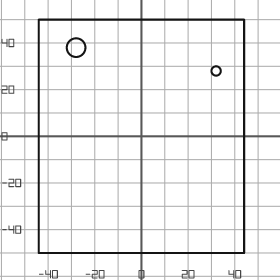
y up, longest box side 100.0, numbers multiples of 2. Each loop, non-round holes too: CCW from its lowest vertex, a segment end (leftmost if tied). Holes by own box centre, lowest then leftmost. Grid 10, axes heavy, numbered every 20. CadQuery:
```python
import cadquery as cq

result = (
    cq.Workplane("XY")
    .moveTo(-44.0, -50.0)
    .lineTo(44.0, -50.0)
    .lineTo(44.0, 50.0)
    .lineTo(-44.0, 50.0)
    .close()
    .moveTo(32.0, 28.0)
    .circle(2.0)
    .moveTo(-28.0, 38.0)
    .circle(4.0)
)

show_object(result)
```